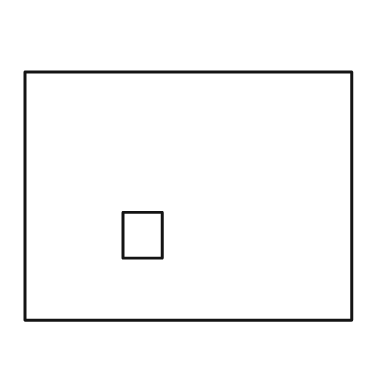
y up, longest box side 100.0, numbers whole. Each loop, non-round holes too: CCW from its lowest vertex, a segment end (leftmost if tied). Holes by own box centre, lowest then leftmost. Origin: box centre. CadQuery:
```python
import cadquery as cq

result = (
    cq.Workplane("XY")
    .moveTo(-50.0, -38.0)
    .lineTo(50.0, -38.0)
    .lineTo(50.0, 38.0)
    .lineTo(-50.0, 38.0)
    .close()
    .moveTo(-20.0, -19.0)
    .lineTo(-8.0, -19.0)
    .lineTo(-8.0, -5.0)
    .lineTo(-20.0, -5.0)
    .close()
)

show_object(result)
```